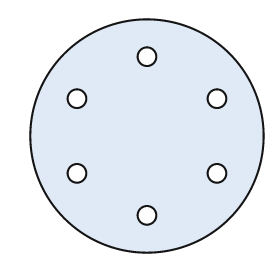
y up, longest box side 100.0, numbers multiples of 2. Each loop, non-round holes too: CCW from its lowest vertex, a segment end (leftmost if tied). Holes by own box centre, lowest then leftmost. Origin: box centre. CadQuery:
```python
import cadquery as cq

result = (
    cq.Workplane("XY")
    .moveTo(0.0, 0.0)
    .circle(50.0)
    .moveTo(0.0, -34.0)
    .circle(4.0)
    .moveTo(-30.0, -16.0)
    .circle(4.0)
    .moveTo(30.0, -16.0)
    .circle(4.0)
    .moveTo(-30.0, 16.0)
    .circle(4.0)
    .moveTo(30.0, 16.0)
    .circle(4.0)
    .moveTo(0.0, 34.0)
    .circle(4.0)
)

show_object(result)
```